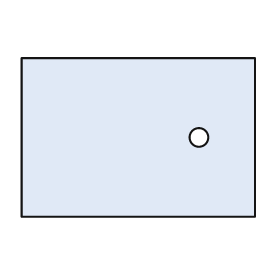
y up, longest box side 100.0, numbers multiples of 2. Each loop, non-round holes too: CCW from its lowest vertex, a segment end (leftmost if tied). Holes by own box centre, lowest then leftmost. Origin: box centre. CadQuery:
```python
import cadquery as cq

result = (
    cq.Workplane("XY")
    .moveTo(-50.0, -34.0)
    .lineTo(50.0, -34.0)
    .lineTo(50.0, 34.0)
    .lineTo(-50.0, 34.0)
    .close()
    .moveTo(26.0, 0.0)
    .circle(4.0)
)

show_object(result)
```